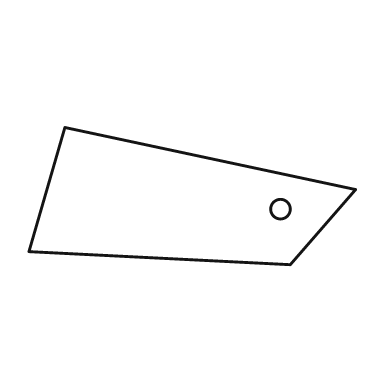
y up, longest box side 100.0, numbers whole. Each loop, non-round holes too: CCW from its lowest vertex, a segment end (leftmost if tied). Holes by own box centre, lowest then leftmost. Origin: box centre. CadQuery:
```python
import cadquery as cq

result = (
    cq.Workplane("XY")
    .moveTo(30.0, -21.0)
    .lineTo(50.0, 2.0)
    .lineTo(-39.0, 21.0)
    .lineTo(-50.0, -17.0)
    .close()
    .moveTo(27.0, -4.0)
    .circle(3.0)
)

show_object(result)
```